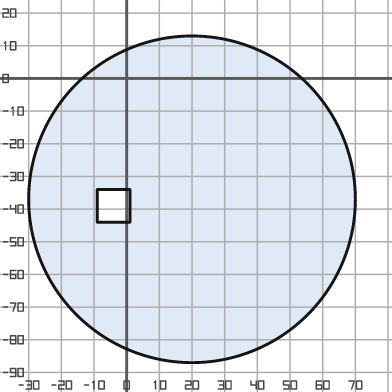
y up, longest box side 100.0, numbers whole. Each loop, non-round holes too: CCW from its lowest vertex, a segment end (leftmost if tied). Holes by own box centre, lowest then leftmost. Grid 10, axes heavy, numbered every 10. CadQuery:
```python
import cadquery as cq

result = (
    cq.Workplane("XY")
    .moveTo(20.0, -37.0)
    .circle(50.0)
    .moveTo(-9.0, -44.0)
    .lineTo(1.0, -44.0)
    .lineTo(1.0, -34.0)
    .lineTo(-9.0, -34.0)
    .close()
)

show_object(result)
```